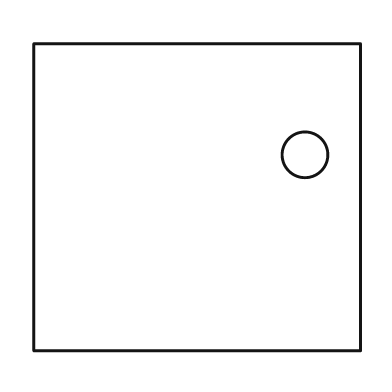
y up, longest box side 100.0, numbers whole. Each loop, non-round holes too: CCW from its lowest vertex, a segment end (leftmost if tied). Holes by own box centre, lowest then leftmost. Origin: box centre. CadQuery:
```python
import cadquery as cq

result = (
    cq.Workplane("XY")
    .moveTo(-50.0, -47.0)
    .lineTo(50.0, -47.0)
    .lineTo(50.0, 47.0)
    .lineTo(-50.0, 47.0)
    .close()
    .moveTo(33.0, 13.0)
    .circle(7.0)
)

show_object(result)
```